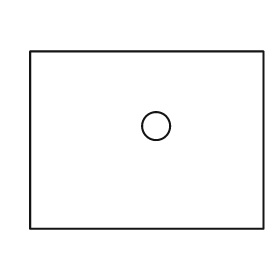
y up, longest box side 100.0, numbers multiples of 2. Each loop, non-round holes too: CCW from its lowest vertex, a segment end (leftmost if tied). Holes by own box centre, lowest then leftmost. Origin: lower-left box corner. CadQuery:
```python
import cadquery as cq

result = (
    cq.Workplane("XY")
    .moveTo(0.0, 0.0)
    .lineTo(100.0, 0.0)
    .lineTo(100.0, 76.0)
    .lineTo(0.0, 76.0)
    .close()
    .moveTo(54.0, 44.0)
    .circle(6.0)
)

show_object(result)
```